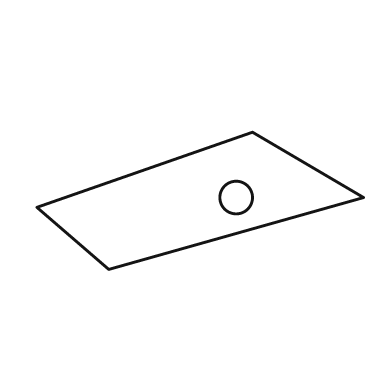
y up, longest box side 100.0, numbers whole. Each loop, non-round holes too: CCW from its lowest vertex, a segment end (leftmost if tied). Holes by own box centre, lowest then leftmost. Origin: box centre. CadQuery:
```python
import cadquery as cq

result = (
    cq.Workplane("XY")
    .moveTo(-28.0, -21.0)
    .lineTo(50.0, 1.0)
    .lineTo(16.0, 21.0)
    .lineTo(-50.0, -2.0)
    .close()
    .moveTo(11.0, 1.0)
    .circle(5.0)
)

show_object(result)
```